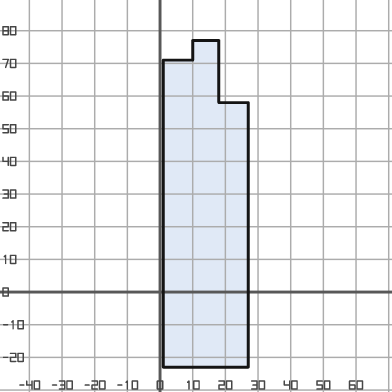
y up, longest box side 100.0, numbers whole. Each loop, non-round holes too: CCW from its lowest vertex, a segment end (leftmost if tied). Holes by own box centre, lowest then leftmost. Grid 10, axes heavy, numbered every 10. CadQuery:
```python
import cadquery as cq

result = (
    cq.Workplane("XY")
    .moveTo(1.0, -23.0)
    .lineTo(27.0, -23.0)
    .lineTo(27.0, 58.0)
    .lineTo(18.0, 58.0)
    .lineTo(18.0, 77.0)
    .lineTo(10.0, 77.0)
    .lineTo(10.0, 71.0)
    .lineTo(1.0, 71.0)
    .close()
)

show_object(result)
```